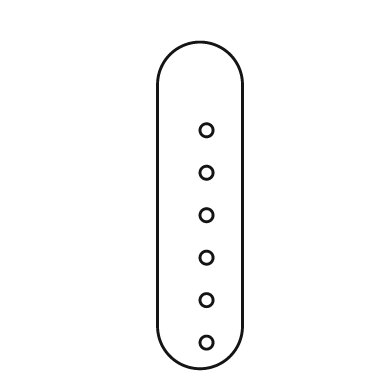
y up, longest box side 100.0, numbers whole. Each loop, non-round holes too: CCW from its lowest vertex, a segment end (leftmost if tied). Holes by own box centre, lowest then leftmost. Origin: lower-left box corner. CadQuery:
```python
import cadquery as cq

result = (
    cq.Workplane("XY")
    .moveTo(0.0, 13.0)
    .threePointArc((13.0, 0.0), (26.0, 13.0))
    .lineTo(26.0, 87.0)
    .threePointArc((13.0, 100.0), (0.0, 87.0))
    .close()
    .moveTo(15.0, 8.0)
    .circle(2.0)
    .moveTo(15.0, 21.0)
    .circle(2.0)
    .moveTo(15.0, 34.0)
    .circle(2.0)
    .moveTo(15.0, 47.0)
    .circle(2.0)
    .moveTo(15.0, 60.0)
    .circle(2.0)
    .moveTo(15.0, 73.0)
    .circle(2.0)
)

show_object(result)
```